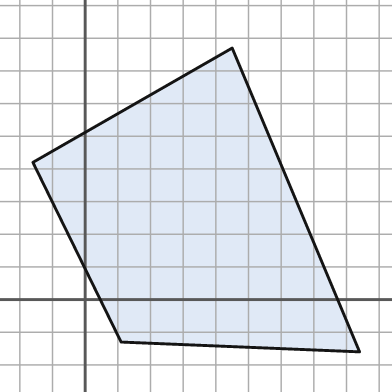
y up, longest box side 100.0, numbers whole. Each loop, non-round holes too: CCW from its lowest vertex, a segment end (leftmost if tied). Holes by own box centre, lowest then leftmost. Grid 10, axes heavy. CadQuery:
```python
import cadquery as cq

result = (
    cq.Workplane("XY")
    .moveTo(84.0, -16.0)
    .lineTo(45.0, 77.0)
    .lineTo(-16.0, 42.0)
    .lineTo(11.0, -13.0)
    .close()
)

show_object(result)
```